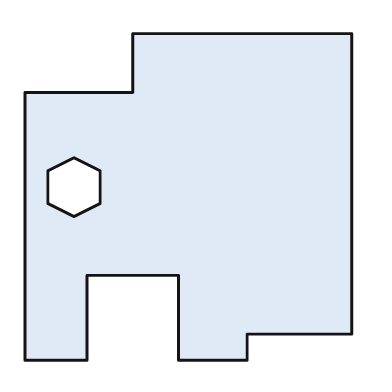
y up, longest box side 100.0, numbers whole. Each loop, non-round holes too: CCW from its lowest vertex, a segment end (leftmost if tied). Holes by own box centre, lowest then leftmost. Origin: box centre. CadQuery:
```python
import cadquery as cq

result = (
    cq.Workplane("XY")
    .moveTo(-50.0, -50.0)
    .lineTo(-31.0, -50.0)
    .lineTo(-31.0, -24.0)
    .lineTo(-3.0, -24.0)
    .lineTo(-3.0, -50.0)
    .lineTo(18.0, -50.0)
    .lineTo(18.0, -42.0)
    .lineTo(50.0, -42.0)
    .lineTo(50.0, 50.0)
    .lineTo(-17.0, 50.0)
    .lineTo(-17.0, 32.0)
    .lineTo(-50.0, 32.0)
    .close()
    .moveTo(-35.0, -6.0)
    .lineTo(-27.0, -2.0)
    .lineTo(-27.0, 8.0)
    .lineTo(-35.0, 12.0)
    .lineTo(-43.0, 8.0)
    .lineTo(-43.0, -2.0)
    .close()
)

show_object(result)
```